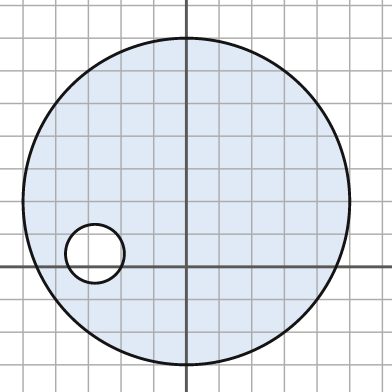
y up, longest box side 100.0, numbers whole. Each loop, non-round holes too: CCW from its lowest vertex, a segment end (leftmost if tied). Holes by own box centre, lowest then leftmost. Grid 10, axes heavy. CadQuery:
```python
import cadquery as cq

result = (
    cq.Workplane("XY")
    .moveTo(0.0, 20.0)
    .circle(50.0)
    .moveTo(-28.0, 4.0)
    .circle(9.0)
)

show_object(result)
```